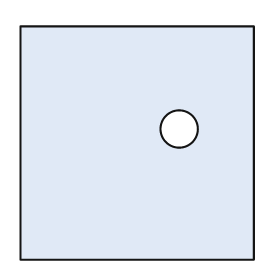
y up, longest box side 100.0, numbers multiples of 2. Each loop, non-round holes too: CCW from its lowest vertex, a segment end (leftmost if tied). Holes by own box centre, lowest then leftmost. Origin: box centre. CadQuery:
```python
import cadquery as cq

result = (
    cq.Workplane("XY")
    .moveTo(-50.0, -50.0)
    .lineTo(50.0, -50.0)
    .lineTo(50.0, 50.0)
    .lineTo(-50.0, 50.0)
    .close()
    .moveTo(18.0, 6.0)
    .circle(8.0)
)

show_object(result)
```